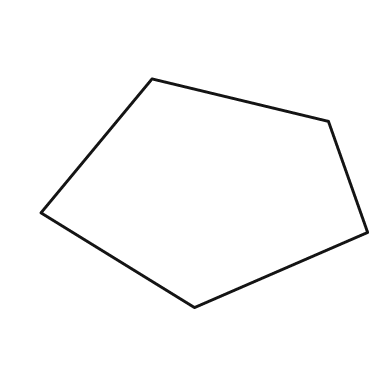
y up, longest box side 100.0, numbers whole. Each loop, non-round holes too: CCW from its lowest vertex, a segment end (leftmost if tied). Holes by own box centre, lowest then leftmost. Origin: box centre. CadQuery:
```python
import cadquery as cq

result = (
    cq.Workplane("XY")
    .moveTo(-3.0, -35.0)
    .lineTo(50.0, -12.0)
    .lineTo(38.0, 22.0)
    .lineTo(-16.0, 35.0)
    .lineTo(-50.0, -6.0)
    .close()
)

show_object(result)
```